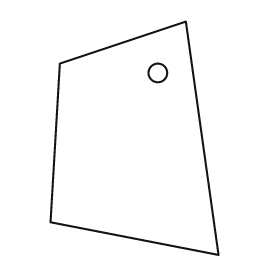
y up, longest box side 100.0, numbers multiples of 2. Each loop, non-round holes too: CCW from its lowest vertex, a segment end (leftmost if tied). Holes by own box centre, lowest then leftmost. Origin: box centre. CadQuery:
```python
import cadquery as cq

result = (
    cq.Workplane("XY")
    .moveTo(36.0, -50.0)
    .lineTo(22.0, 50.0)
    .lineTo(-32.0, 32.0)
    .lineTo(-36.0, -36.0)
    .close()
    .moveTo(10.0, 28.0)
    .circle(4.0)
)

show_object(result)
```